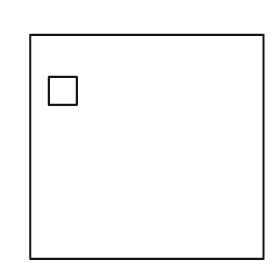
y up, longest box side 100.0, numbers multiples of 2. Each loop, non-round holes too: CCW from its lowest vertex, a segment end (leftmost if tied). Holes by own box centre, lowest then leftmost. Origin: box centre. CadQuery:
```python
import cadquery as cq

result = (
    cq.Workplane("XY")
    .moveTo(-50.0, -48.0)
    .lineTo(50.0, -48.0)
    .lineTo(50.0, 48.0)
    .lineTo(-50.0, 48.0)
    .close()
    .moveTo(-42.0, 18.0)
    .lineTo(-30.0, 18.0)
    .lineTo(-30.0, 30.0)
    .lineTo(-42.0, 30.0)
    .close()
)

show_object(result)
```